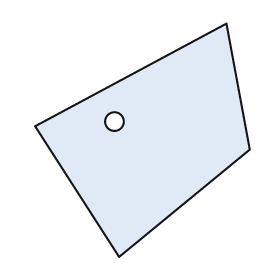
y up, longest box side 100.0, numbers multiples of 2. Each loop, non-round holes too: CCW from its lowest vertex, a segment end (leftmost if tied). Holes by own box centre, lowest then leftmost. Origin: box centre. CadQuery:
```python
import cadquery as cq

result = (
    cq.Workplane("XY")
    .moveTo(-10.0, -50.0)
    .lineTo(46.0, -4.0)
    .lineTo(36.0, 50.0)
    .lineTo(-46.0, 6.0)
    .close()
    .moveTo(-12.0, 8.0)
    .circle(4.0)
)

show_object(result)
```